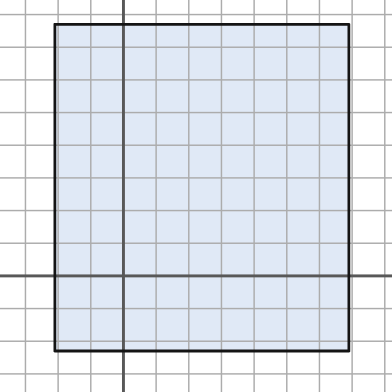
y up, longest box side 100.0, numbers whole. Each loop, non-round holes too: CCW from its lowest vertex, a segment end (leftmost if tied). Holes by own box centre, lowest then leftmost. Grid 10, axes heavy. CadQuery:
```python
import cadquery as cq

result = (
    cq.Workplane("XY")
    .moveTo(-21.0, -23.0)
    .lineTo(69.0, -23.0)
    .lineTo(69.0, 77.0)
    .lineTo(-21.0, 77.0)
    .close()
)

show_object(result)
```